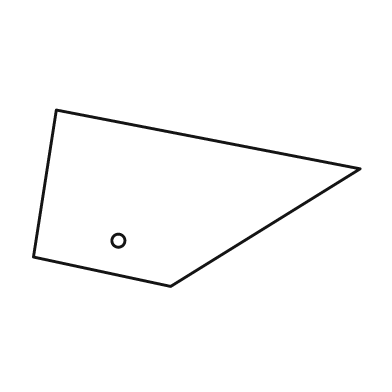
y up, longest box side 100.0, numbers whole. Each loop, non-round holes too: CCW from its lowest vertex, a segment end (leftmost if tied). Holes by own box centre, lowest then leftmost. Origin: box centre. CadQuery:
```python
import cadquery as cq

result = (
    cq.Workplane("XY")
    .moveTo(-8.0, -27.0)
    .lineTo(50.0, 9.0)
    .lineTo(-43.0, 27.0)
    .lineTo(-50.0, -18.0)
    .close()
    .moveTo(-24.0, -13.0)
    .circle(2.0)
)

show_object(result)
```